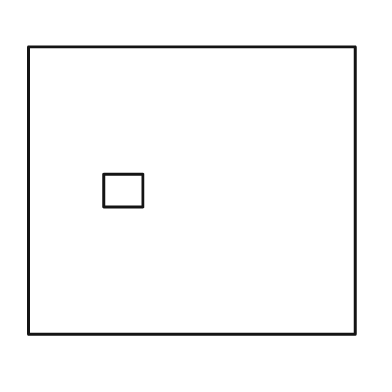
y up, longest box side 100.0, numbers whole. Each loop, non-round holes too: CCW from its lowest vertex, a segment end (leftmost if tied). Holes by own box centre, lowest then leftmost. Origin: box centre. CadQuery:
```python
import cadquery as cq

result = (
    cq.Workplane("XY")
    .moveTo(-50.0, -44.0)
    .lineTo(50.0, -44.0)
    .lineTo(50.0, 44.0)
    .lineTo(-50.0, 44.0)
    .close()
    .moveTo(-27.0, -5.0)
    .lineTo(-15.0, -5.0)
    .lineTo(-15.0, 5.0)
    .lineTo(-27.0, 5.0)
    .close()
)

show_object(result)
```